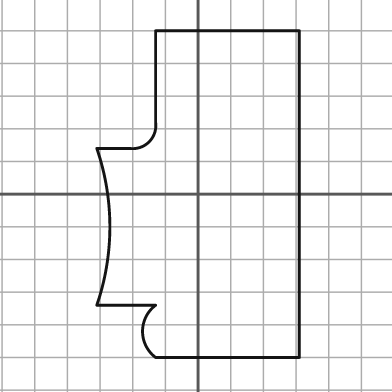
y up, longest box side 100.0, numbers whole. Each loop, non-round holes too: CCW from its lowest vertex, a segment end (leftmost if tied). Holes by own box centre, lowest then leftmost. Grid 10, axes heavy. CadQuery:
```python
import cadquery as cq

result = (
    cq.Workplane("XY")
    .moveTo(-13.0, -50.0)
    .lineTo(31.0, -50.0)
    .lineTo(31.0, 50.0)
    .lineTo(-13.0, 50.0)
    .lineTo(-13.0, 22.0)
    .threePointArc((-15.0, 16.0), (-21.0, 14.0))
    .lineTo(-31.0, 14.0)
    .threePointArc((-27.0, -10.0), (-31.0, -34.0))
    .lineTo(-13.0, -34.0)
    .threePointArc((-17.0, -42.0), (-13.0, -50.0))
    .close()
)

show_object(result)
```